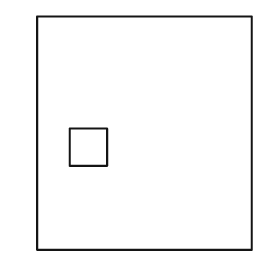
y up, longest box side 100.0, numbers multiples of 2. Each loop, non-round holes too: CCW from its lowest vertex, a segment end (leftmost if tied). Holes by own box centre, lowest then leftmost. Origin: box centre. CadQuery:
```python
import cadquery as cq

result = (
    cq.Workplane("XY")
    .moveTo(-46.0, -50.0)
    .lineTo(46.0, -50.0)
    .lineTo(46.0, 50.0)
    .lineTo(-46.0, 50.0)
    .close()
    .moveTo(-32.0, -14.0)
    .lineTo(-16.0, -14.0)
    .lineTo(-16.0, 2.0)
    .lineTo(-32.0, 2.0)
    .close()
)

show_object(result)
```